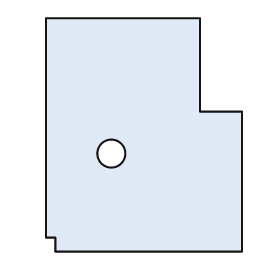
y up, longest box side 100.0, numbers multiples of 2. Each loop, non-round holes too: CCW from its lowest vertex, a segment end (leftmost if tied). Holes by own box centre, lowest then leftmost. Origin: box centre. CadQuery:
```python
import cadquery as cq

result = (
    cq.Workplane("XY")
    .moveTo(-38.0, -50.0)
    .lineTo(42.0, -50.0)
    .lineTo(42.0, 10.0)
    .lineTo(24.0, 10.0)
    .lineTo(24.0, 50.0)
    .lineTo(-42.0, 50.0)
    .lineTo(-42.0, -44.0)
    .lineTo(-38.0, -44.0)
    .close()
    .moveTo(-14.0, -8.0)
    .circle(6.0)
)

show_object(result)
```